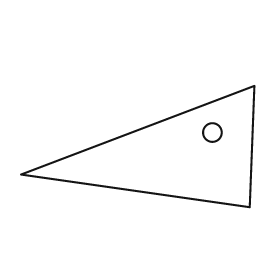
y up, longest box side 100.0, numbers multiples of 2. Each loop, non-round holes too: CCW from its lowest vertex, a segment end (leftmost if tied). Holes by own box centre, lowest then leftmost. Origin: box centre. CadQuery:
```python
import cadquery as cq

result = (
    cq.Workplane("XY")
    .moveTo(48.0, -26.0)
    .lineTo(50.0, 26.0)
    .lineTo(-50.0, -12.0)
    .close()
    .moveTo(32.0, 6.0)
    .circle(4.0)
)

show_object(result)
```